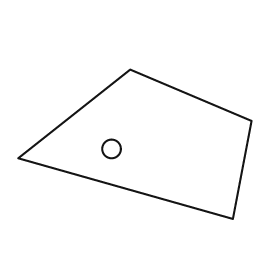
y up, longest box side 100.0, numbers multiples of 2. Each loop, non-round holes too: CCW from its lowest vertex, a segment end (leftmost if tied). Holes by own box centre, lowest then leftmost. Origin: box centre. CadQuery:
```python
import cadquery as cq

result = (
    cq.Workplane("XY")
    .moveTo(42.0, -32.0)
    .lineTo(50.0, 10.0)
    .lineTo(-2.0, 32.0)
    .lineTo(-50.0, -6.0)
    .close()
    .moveTo(-10.0, -2.0)
    .circle(4.0)
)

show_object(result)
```